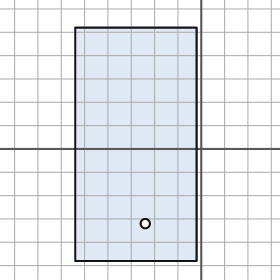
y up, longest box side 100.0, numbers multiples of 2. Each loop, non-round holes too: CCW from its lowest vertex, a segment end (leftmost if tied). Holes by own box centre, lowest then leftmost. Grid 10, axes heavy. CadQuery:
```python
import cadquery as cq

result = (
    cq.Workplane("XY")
    .moveTo(-54.0, -48.0)
    .lineTo(-2.0, -48.0)
    .lineTo(-2.0, 52.0)
    .lineTo(-54.0, 52.0)
    .close()
    .moveTo(-24.0, -32.0)
    .circle(2.0)
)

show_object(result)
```